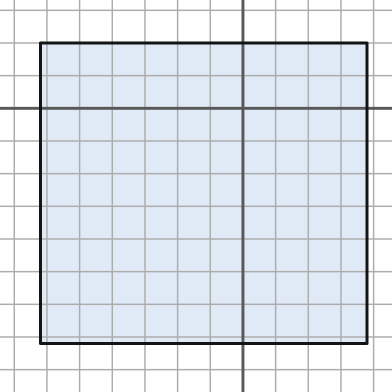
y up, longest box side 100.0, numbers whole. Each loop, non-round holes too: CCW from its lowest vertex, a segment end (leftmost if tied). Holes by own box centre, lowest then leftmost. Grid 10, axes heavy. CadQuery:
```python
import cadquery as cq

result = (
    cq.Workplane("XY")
    .moveTo(-62.0, -72.0)
    .lineTo(38.0, -72.0)
    .lineTo(38.0, 20.0)
    .lineTo(-62.0, 20.0)
    .close()
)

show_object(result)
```